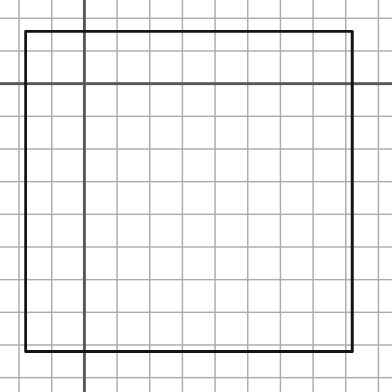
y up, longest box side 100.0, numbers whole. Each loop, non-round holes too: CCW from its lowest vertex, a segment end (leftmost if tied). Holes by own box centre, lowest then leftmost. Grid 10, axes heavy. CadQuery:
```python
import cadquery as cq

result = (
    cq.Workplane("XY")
    .moveTo(-18.0, -82.0)
    .lineTo(82.0, -82.0)
    .lineTo(82.0, 16.0)
    .lineTo(-18.0, 16.0)
    .close()
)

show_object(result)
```